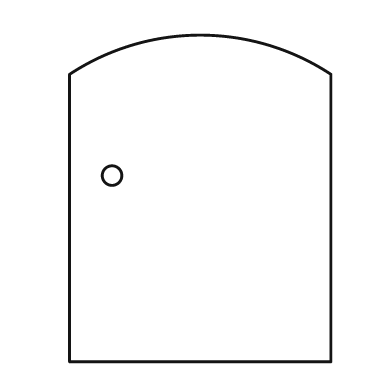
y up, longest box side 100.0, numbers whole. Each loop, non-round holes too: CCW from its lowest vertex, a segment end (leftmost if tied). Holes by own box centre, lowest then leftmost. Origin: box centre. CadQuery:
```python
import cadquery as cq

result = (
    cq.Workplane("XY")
    .moveTo(-40.0, -50.0)
    .lineTo(40.0, -50.0)
    .lineTo(40.0, 38.0)
    .threePointArc((0.0, 50.0), (-40.0, 38.0))
    .close()
    .moveTo(-27.0, 7.0)
    .circle(3.0)
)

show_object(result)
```